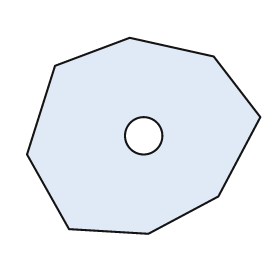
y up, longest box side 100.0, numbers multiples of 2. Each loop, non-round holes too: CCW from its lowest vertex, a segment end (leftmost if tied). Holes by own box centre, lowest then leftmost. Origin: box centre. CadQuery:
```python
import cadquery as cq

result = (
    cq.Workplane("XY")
    .moveTo(2.0, -42.0)
    .lineTo(32.0, -26.0)
    .lineTo(50.0, 8.0)
    .lineTo(30.0, 34.0)
    .lineTo(-6.0, 42.0)
    .lineTo(-38.0, 30.0)
    .lineTo(-50.0, -8.0)
    .lineTo(-32.0, -40.0)
    .close()
    .moveTo(0.0, 0.0)
    .circle(8.0)
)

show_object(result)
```